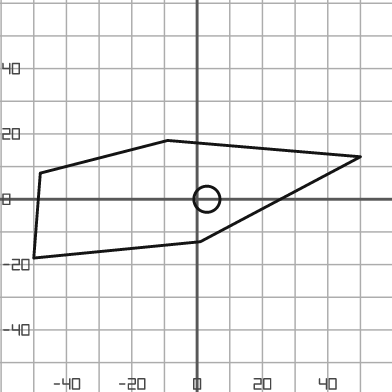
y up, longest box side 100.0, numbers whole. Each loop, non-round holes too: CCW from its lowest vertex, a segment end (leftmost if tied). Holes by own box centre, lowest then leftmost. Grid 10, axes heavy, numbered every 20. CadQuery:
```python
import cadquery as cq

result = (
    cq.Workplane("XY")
    .moveTo(-50.0, -18.0)
    .lineTo(1.0, -13.0)
    .lineTo(50.0, 13.0)
    .lineTo(-9.0, 18.0)
    .lineTo(-48.0, 8.0)
    .close()
    .moveTo(3.0, 0.0)
    .circle(4.0)
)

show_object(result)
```